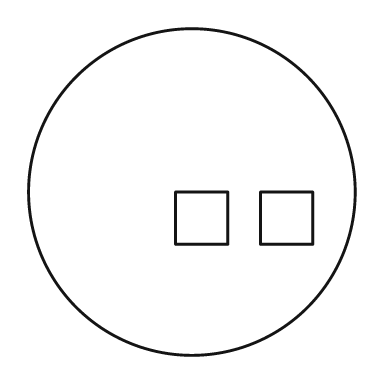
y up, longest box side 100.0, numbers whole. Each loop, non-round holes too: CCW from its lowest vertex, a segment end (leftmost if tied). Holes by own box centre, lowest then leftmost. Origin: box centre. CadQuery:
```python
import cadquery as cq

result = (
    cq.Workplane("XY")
    .moveTo(0.0, 0.0)
    .circle(50.0)
    .moveTo(-5.0, -16.0)
    .lineTo(11.0, -16.0)
    .lineTo(11.0, 0.0)
    .lineTo(-5.0, 0.0)
    .close()
    .moveTo(21.0, -16.0)
    .lineTo(37.0, -16.0)
    .lineTo(37.0, 0.0)
    .lineTo(21.0, 0.0)
    .close()
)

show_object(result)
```